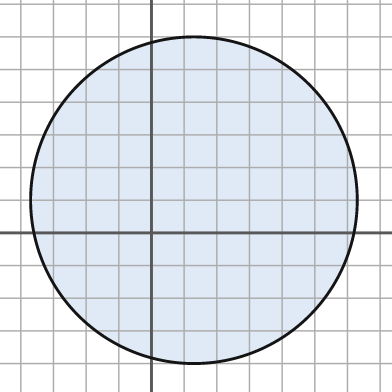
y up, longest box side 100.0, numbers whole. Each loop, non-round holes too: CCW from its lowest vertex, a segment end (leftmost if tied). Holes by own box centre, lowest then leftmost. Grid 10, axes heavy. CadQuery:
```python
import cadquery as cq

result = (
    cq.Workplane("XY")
    .moveTo(13.0, 10.0)
    .circle(50.0)
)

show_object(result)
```